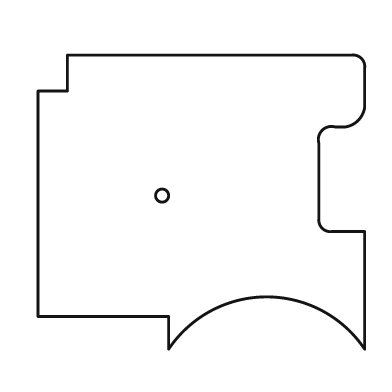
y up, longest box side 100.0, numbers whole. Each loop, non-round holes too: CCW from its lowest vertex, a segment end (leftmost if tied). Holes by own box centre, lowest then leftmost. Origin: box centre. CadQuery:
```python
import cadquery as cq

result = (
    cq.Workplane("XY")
    .moveTo(-10.0, -45.0)
    .threePointArc((20.0, -29.0), (50.0, -45.0))
    .lineTo(50.0, -9.0)
    .lineTo(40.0, -9.0)
    .threePointArc((37.0, -8.0), (36.0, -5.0))
    .lineTo(36.0, 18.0)
    .threePointArc((37.0, 22.0), (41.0, 23.0))
    .lineTo(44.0, 23.0)
    .threePointArc((48.0, 25.0), (50.0, 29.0))
    .lineTo(50.0, 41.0)
    .threePointArc((49.0, 44.0), (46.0, 45.0))
    .lineTo(-41.0, 45.0)
    .lineTo(-41.0, 34.0)
    .lineTo(-50.0, 34.0)
    .lineTo(-50.0, -35.0)
    .lineTo(-10.0, -35.0)
    .close()
    .moveTo(-12.0, 2.0)
    .circle(2.0)
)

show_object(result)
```